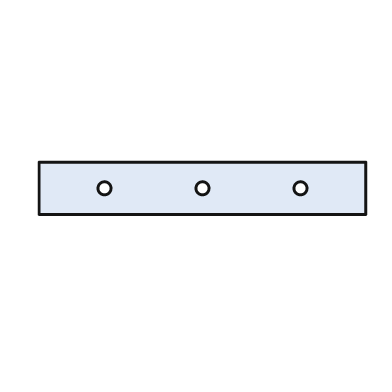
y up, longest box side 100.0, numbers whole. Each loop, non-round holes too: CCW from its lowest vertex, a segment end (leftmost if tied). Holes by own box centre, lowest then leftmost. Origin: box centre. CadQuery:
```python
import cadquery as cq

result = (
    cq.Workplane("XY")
    .moveTo(-50.0, -8.0)
    .lineTo(50.0, -8.0)
    .lineTo(50.0, 8.0)
    .lineTo(-50.0, 8.0)
    .close()
    .moveTo(-30.0, 0.0)
    .circle(2.0)
    .moveTo(0.0, 0.0)
    .circle(2.0)
    .moveTo(30.0, 0.0)
    .circle(2.0)
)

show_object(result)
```